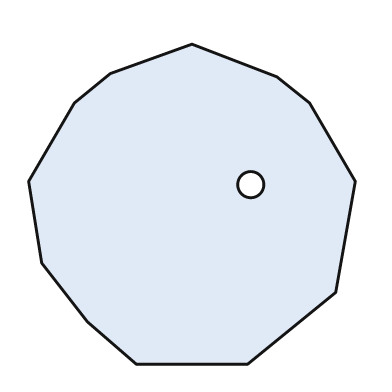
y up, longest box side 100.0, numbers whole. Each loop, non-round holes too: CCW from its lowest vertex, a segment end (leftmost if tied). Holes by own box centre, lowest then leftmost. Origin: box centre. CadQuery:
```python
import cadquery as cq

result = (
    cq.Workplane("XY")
    .moveTo(-17.0, -49.0)
    .lineTo(17.0, -49.0)
    .lineTo(44.0, -27.0)
    .lineTo(50.0, 7.0)
    .lineTo(36.0, 31.0)
    .lineTo(26.0, 39.0)
    .lineTo(0.0, 49.0)
    .lineTo(-25.0, 40.0)
    .lineTo(-36.0, 31.0)
    .lineTo(-50.0, 7.0)
    .lineTo(-46.0, -18.0)
    .lineTo(-32.0, -36.0)
    .close()
    .moveTo(18.0, 6.0)
    .circle(4.0)
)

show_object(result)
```